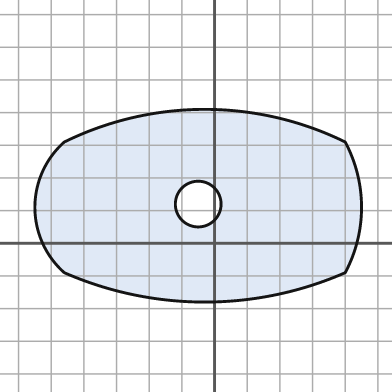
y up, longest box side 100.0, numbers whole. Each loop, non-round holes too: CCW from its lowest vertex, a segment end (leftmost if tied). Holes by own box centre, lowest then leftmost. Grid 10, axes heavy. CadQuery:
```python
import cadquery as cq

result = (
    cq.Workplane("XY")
    .moveTo(-46.0, -9.0)
    .threePointArc((-3.0, -18.0), (40.0, -9.0))
    .threePointArc((45.0, 11.0), (40.0, 31.0))
    .threePointArc((-3.0, 41.0), (-46.0, 31.0))
    .threePointArc((-55.0, 11.0), (-46.0, -9.0))
    .close()
    .moveTo(-5.0, 12.0)
    .circle(7.0)
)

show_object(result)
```